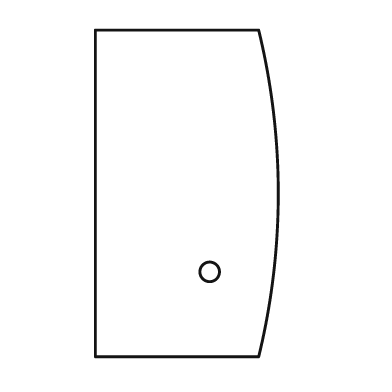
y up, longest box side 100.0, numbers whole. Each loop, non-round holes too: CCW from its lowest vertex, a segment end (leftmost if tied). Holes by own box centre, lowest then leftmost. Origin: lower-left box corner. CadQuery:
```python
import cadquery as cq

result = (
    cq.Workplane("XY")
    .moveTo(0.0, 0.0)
    .lineTo(50.0, 0.0)
    .threePointArc((56.0, 50.0), (50.0, 100.0))
    .lineTo(0.0, 100.0)
    .close()
    .moveTo(35.0, 26.0)
    .circle(3.0)
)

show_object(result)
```